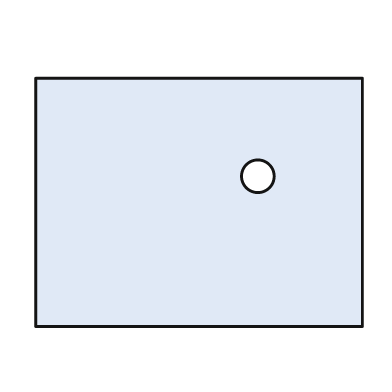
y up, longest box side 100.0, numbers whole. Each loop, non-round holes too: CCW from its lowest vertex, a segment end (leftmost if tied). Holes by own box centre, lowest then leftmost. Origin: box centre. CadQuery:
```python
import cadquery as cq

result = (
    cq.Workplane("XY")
    .moveTo(-50.0, -38.0)
    .lineTo(50.0, -38.0)
    .lineTo(50.0, 38.0)
    .lineTo(-50.0, 38.0)
    .close()
    .moveTo(18.0, 8.0)
    .circle(5.0)
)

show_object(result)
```